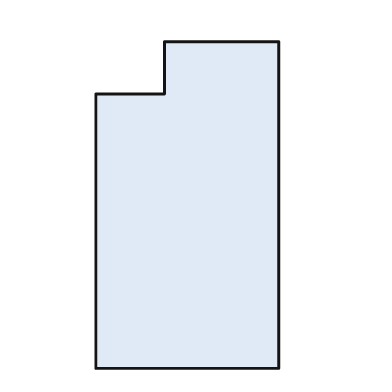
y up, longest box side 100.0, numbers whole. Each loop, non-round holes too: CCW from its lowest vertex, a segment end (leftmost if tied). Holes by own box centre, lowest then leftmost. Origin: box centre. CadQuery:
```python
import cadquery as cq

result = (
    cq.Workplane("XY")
    .moveTo(-28.0, -50.0)
    .lineTo(28.0, -50.0)
    .lineTo(28.0, 50.0)
    .lineTo(-7.0, 50.0)
    .lineTo(-7.0, 34.0)
    .lineTo(-28.0, 34.0)
    .close()
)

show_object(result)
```